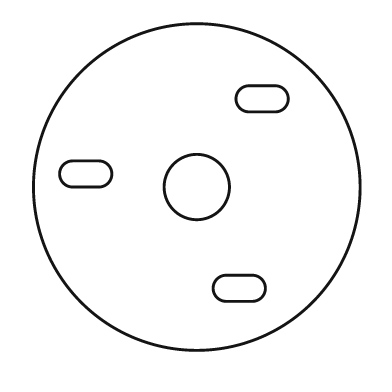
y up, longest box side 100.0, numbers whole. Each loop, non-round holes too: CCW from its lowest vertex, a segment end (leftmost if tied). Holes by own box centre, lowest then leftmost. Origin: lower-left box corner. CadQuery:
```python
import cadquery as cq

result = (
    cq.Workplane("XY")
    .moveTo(50.0, 50.0)
    .circle(50.0)
    .moveTo(59.0, 15.0)
    .lineTo(67.0, 15.0)
    .threePointArc((71.0, 19.0), (67.0, 23.0))
    .lineTo(59.0, 23.0)
    .threePointArc((55.0, 19.0), (59.0, 15.0))
    .close()
    .moveTo(50.0, 50.0)
    .circle(10.0)
    .moveTo(12.0, 50.0)
    .lineTo(20.0, 50.0)
    .threePointArc((24.0, 54.0), (20.0, 58.0))
    .lineTo(12.0, 58.0)
    .threePointArc((8.0, 54.0), (12.0, 50.0))
    .close()
    .moveTo(66.0, 73.0)
    .lineTo(74.0, 73.0)
    .threePointArc((78.0, 77.0), (74.0, 81.0))
    .lineTo(66.0, 81.0)
    .threePointArc((62.0, 77.0), (66.0, 73.0))
    .close()
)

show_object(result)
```